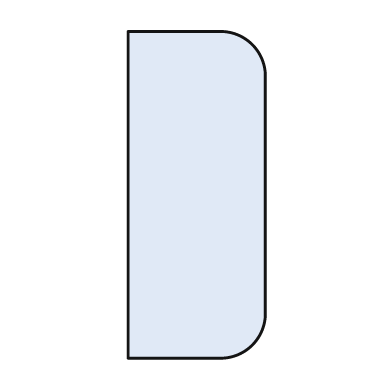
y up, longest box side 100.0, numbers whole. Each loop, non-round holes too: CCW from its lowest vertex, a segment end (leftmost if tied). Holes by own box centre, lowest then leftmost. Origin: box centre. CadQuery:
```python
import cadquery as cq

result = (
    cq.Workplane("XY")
    .moveTo(-21.0, -50.0)
    .lineTo(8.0, -50.0)
    .threePointArc((17.0, -46.0), (21.0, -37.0))
    .lineTo(21.0, 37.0)
    .threePointArc((17.0, 46.0), (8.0, 50.0))
    .lineTo(-21.0, 50.0)
    .close()
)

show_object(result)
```